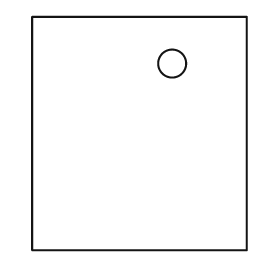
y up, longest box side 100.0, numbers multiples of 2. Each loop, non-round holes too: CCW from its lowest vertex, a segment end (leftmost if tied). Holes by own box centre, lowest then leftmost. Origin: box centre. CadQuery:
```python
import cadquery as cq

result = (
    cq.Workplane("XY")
    .moveTo(-46.0, -50.0)
    .lineTo(46.0, -50.0)
    .lineTo(46.0, 50.0)
    .lineTo(-46.0, 50.0)
    .close()
    .moveTo(14.0, 30.0)
    .circle(6.0)
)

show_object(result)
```